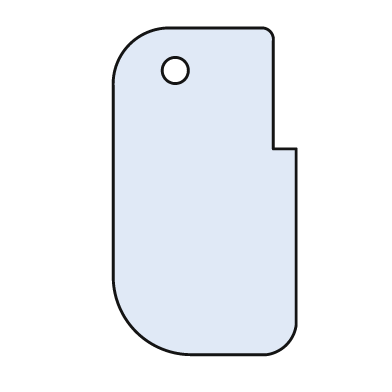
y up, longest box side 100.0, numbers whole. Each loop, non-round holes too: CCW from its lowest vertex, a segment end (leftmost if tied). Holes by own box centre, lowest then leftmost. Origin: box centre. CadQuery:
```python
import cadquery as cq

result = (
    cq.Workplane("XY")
    .moveTo(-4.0, -50.0)
    .lineTo(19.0, -50.0)
    .threePointArc((25.0, -47.0), (28.0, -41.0))
    .lineTo(28.0, 13.0)
    .lineTo(21.0, 13.0)
    .lineTo(21.0, 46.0)
    .threePointArc((20.0, 49.0), (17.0, 50.0))
    .lineTo(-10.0, 50.0)
    .threePointArc((-23.0, 45.0), (-28.0, 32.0))
    .lineTo(-28.0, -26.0)
    .threePointArc((-21.0, -43.0), (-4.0, -50.0))
    .close()
    .moveTo(-9.0, 37.0)
    .circle(4.0)
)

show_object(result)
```